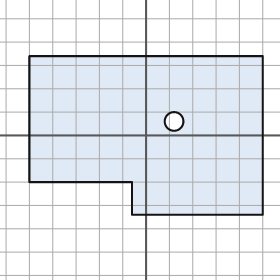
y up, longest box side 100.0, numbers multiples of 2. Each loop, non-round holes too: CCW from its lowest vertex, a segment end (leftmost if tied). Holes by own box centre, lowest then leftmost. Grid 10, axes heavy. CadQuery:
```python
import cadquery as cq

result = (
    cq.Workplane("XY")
    .moveTo(-6.0, -34.0)
    .lineTo(50.0, -34.0)
    .lineTo(50.0, 34.0)
    .lineTo(-50.0, 34.0)
    .lineTo(-50.0, -20.0)
    .lineTo(-6.0, -20.0)
    .close()
    .moveTo(12.0, 6.0)
    .circle(4.0)
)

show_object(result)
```